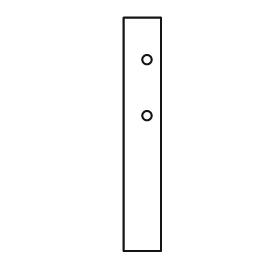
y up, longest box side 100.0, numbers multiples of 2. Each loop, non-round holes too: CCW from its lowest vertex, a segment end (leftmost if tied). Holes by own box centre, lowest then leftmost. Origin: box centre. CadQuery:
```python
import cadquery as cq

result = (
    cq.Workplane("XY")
    .moveTo(-8.0, -50.0)
    .lineTo(8.0, -50.0)
    .lineTo(8.0, 50.0)
    .lineTo(-8.0, 50.0)
    .close()
    .moveTo(2.0, 8.0)
    .circle(2.0)
    .moveTo(2.0, 32.0)
    .circle(2.0)
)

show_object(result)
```